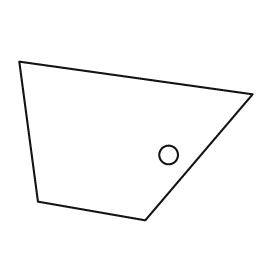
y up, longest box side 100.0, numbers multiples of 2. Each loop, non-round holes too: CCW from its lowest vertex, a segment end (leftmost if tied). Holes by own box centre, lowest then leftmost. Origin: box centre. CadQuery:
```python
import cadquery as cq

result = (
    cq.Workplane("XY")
    .moveTo(4.0, -34.0)
    .lineTo(50.0, 20.0)
    .lineTo(-50.0, 34.0)
    .lineTo(-42.0, -26.0)
    .close()
    .moveTo(14.0, -6.0)
    .circle(4.0)
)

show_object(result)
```